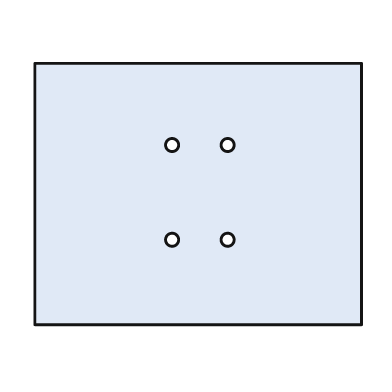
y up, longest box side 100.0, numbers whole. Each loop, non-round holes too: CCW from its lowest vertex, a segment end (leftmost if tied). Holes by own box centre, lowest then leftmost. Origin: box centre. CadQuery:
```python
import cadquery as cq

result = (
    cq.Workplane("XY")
    .moveTo(-50.0, -40.0)
    .lineTo(50.0, -40.0)
    .lineTo(50.0, 40.0)
    .lineTo(-50.0, 40.0)
    .close()
    .moveTo(-8.0, -14.0)
    .circle(2.0)
    .moveTo(9.0, -14.0)
    .circle(2.0)
    .moveTo(-8.0, 15.0)
    .circle(2.0)
    .moveTo(9.0, 15.0)
    .circle(2.0)
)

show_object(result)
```